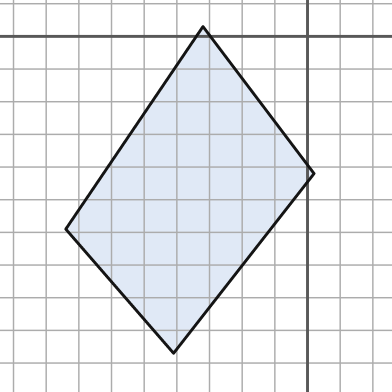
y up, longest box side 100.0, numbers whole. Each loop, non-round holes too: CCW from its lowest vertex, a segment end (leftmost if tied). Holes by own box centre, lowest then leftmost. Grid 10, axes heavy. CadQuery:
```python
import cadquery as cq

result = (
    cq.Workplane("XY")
    .moveTo(-41.0, -97.0)
    .lineTo(2.0, -42.0)
    .lineTo(-32.0, 3.0)
    .lineTo(-74.0, -59.0)
    .close()
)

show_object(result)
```